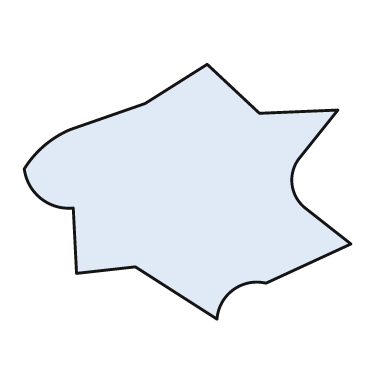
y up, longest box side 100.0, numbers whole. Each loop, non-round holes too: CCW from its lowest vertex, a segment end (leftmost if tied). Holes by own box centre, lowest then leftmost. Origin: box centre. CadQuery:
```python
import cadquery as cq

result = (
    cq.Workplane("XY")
    .moveTo(9.0, -39.0)
    .threePointArc((14.0, -30.0), (24.0, -28.0))
    .lineTo(50.0, -16.0)
    .lineTo(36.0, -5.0)
    .threePointArc((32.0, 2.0), (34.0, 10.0))
    .lineTo(46.0, 25.0)
    .lineTo(22.0, 24.0)
    .lineTo(6.0, 39.0)
    .lineTo(-13.0, 27.0)
    .lineTo(-36.0, 19.0)
    .threePointArc((-44.0, 14.0), (-50.0, 7.0))
    .threePointArc((-45.0, -2.0), (-35.0, -5.0))
    .lineTo(-34.0, -25.0)
    .lineTo(-16.0, -23.0)
    .close()
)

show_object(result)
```